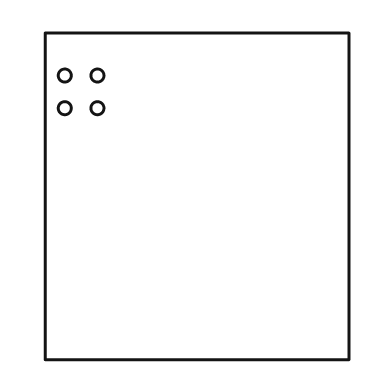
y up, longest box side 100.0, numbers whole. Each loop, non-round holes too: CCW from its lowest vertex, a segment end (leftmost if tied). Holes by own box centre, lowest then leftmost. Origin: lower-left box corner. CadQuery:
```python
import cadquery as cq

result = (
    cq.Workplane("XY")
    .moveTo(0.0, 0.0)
    .lineTo(93.0, 0.0)
    .lineTo(93.0, 100.0)
    .lineTo(0.0, 100.0)
    .close()
    .moveTo(6.0, 77.0)
    .circle(2.0)
    .moveTo(16.0, 77.0)
    .circle(2.0)
    .moveTo(6.0, 87.0)
    .circle(2.0)
    .moveTo(16.0, 87.0)
    .circle(2.0)
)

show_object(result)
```